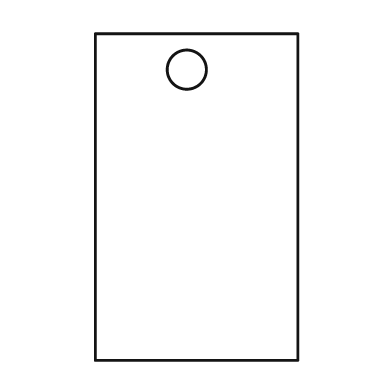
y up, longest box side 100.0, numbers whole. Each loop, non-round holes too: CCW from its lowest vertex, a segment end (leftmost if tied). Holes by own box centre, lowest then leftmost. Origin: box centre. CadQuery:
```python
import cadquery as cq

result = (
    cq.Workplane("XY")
    .moveTo(-31.0, -50.0)
    .lineTo(31.0, -50.0)
    .lineTo(31.0, 50.0)
    .lineTo(-31.0, 50.0)
    .close()
    .moveTo(-3.0, 39.0)
    .circle(6.0)
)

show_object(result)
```